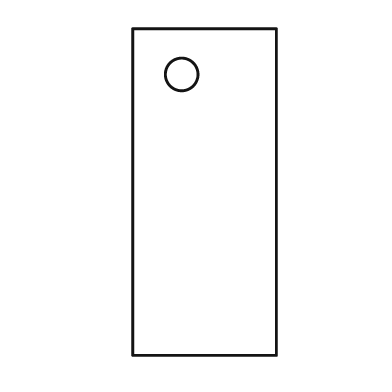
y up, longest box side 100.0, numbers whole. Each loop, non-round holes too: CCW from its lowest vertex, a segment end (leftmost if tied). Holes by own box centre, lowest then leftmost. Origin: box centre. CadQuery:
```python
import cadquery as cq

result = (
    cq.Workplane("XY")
    .moveTo(-22.0, -50.0)
    .lineTo(22.0, -50.0)
    .lineTo(22.0, 50.0)
    .lineTo(-22.0, 50.0)
    .close()
    .moveTo(-7.0, 36.0)
    .circle(5.0)
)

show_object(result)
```